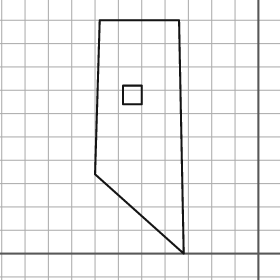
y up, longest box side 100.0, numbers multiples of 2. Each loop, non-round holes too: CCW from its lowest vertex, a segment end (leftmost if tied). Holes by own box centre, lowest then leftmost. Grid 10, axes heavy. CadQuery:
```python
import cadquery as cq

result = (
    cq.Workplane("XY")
    .moveTo(-32.0, 0.0)
    .lineTo(-34.0, 100.0)
    .lineTo(-68.0, 100.0)
    .lineTo(-70.0, 34.0)
    .close()
    .moveTo(-58.0, 64.0)
    .lineTo(-50.0, 64.0)
    .lineTo(-50.0, 72.0)
    .lineTo(-58.0, 72.0)
    .close()
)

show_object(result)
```